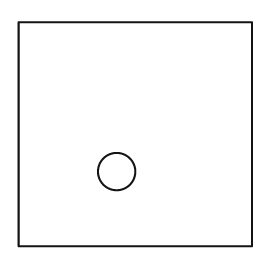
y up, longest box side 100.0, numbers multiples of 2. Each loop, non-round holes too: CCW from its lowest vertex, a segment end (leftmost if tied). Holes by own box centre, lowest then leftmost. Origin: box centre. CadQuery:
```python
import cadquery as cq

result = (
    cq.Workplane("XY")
    .moveTo(-50.0, -48.0)
    .lineTo(50.0, -48.0)
    .lineTo(50.0, 48.0)
    .lineTo(-50.0, 48.0)
    .close()
    .moveTo(-8.0, -16.0)
    .circle(8.0)
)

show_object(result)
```